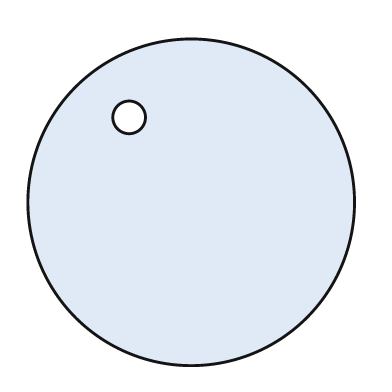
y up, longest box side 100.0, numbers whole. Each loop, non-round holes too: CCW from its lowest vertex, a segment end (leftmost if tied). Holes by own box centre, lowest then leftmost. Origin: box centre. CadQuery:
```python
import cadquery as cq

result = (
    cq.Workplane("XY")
    .moveTo(0.0, 0.0)
    .circle(50.0)
    .moveTo(-19.0, 26.0)
    .circle(5.0)
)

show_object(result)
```